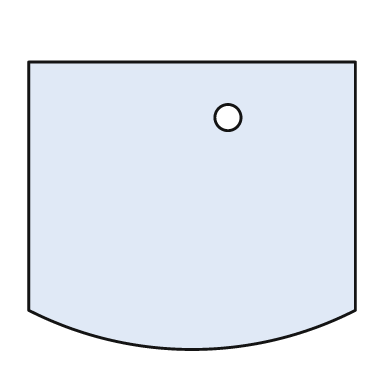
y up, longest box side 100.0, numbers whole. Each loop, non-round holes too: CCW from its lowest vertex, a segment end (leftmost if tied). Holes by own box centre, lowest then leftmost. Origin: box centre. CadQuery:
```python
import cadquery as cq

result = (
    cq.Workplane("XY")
    .moveTo(-50.0, -32.0)
    .threePointArc((0.0, -44.0), (50.0, -32.0))
    .lineTo(50.0, 44.0)
    .lineTo(-50.0, 44.0)
    .close()
    .moveTo(11.0, 27.0)
    .circle(4.0)
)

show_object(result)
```